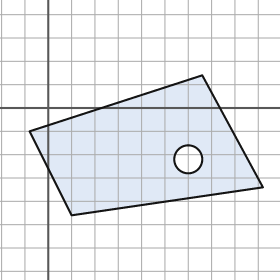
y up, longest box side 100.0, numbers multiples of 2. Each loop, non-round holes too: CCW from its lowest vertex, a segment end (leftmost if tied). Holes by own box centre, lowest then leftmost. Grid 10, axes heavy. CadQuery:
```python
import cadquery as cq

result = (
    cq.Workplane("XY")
    .moveTo(10.0, -46.0)
    .lineTo(92.0, -34.0)
    .lineTo(66.0, 14.0)
    .lineTo(-8.0, -10.0)
    .close()
    .moveTo(60.0, -22.0)
    .circle(6.0)
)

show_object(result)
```